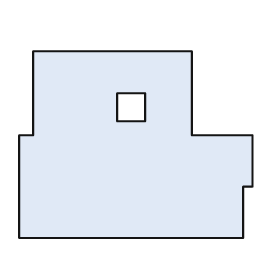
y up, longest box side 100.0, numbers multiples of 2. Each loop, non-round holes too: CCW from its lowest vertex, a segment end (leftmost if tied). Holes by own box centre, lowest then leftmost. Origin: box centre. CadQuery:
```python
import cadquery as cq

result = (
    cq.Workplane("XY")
    .moveTo(-50.0, -40.0)
    .lineTo(46.0, -40.0)
    .lineTo(46.0, -18.0)
    .lineTo(50.0, -18.0)
    .lineTo(50.0, 4.0)
    .lineTo(24.0, 4.0)
    .lineTo(24.0, 40.0)
    .lineTo(-44.0, 40.0)
    .lineTo(-44.0, 4.0)
    .lineTo(-50.0, 4.0)
    .close()
    .moveTo(-8.0, 10.0)
    .lineTo(4.0, 10.0)
    .lineTo(4.0, 22.0)
    .lineTo(-8.0, 22.0)
    .close()
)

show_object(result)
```